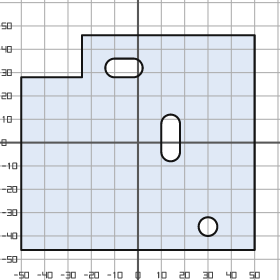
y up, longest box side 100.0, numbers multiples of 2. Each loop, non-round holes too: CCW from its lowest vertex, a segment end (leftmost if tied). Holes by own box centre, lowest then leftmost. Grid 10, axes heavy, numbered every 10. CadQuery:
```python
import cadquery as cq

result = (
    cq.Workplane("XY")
    .moveTo(-50.0, -46.0)
    .lineTo(50.0, -46.0)
    .lineTo(50.0, 46.0)
    .lineTo(-24.0, 46.0)
    .lineTo(-24.0, 28.0)
    .lineTo(-50.0, 28.0)
    .close()
    .moveTo(30.0, -36.0)
    .circle(4.0)
    .moveTo(10.0, -4.0)
    .threePointArc((14.0, -8.0), (18.0, -4.0))
    .lineTo(18.0, 8.0)
    .threePointArc((14.0, 12.0), (10.0, 8.0))
    .close()
    .moveTo(-10.0, 28.0)
    .lineTo(-2.0, 28.0)
    .threePointArc((2.0, 32.0), (-2.0, 36.0))
    .lineTo(-10.0, 36.0)
    .threePointArc((-14.0, 32.0), (-10.0, 28.0))
    .close()
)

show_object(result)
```